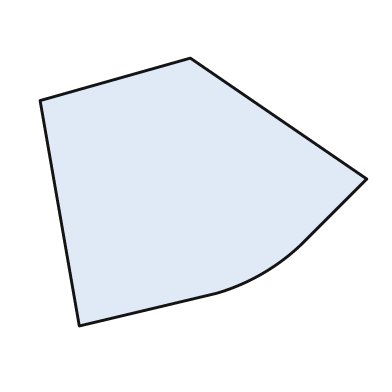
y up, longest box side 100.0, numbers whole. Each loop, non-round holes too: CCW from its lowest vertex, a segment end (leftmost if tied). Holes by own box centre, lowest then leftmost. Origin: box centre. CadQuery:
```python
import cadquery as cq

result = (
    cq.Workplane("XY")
    .moveTo(-38.0, -41.0)
    .lineTo(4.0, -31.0)
    .threePointArc((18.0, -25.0), (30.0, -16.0))
    .lineTo(50.0, 4.0)
    .lineTo(-4.0, 41.0)
    .lineTo(-50.0, 28.0)
    .close()
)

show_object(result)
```